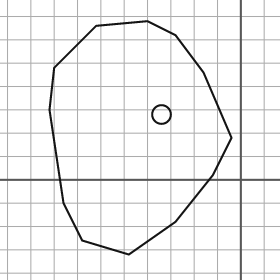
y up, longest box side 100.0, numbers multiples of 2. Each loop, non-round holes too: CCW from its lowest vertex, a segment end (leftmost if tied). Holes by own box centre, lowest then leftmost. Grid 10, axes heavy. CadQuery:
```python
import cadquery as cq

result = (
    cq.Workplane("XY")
    .moveTo(-48.0, -32.0)
    .lineTo(-28.0, -18.0)
    .lineTo(-12.0, 2.0)
    .lineTo(-4.0, 18.0)
    .lineTo(-16.0, 46.0)
    .lineTo(-28.0, 62.0)
    .lineTo(-40.0, 68.0)
    .lineTo(-62.0, 66.0)
    .lineTo(-80.0, 48.0)
    .lineTo(-82.0, 30.0)
    .lineTo(-76.0, -10.0)
    .lineTo(-68.0, -26.0)
    .close()
    .moveTo(-34.0, 28.0)
    .circle(4.0)
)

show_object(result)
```